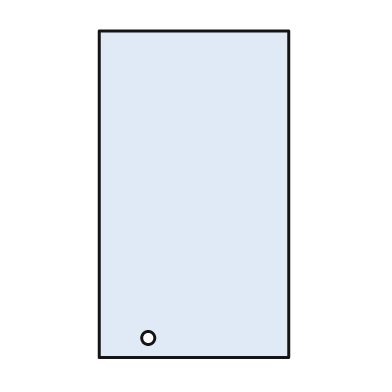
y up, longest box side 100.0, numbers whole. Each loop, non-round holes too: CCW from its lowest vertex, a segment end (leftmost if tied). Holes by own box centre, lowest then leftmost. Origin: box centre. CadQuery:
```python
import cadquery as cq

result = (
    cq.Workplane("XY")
    .moveTo(-29.0, -50.0)
    .lineTo(29.0, -50.0)
    .lineTo(29.0, 50.0)
    .lineTo(-29.0, 50.0)
    .close()
    .moveTo(-14.0, -44.0)
    .circle(2.0)
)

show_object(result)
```